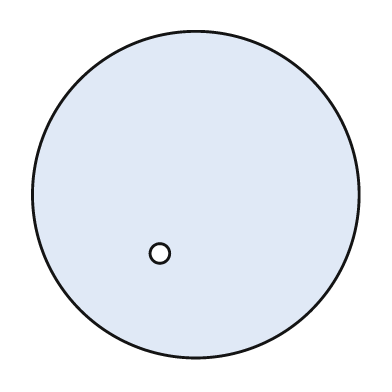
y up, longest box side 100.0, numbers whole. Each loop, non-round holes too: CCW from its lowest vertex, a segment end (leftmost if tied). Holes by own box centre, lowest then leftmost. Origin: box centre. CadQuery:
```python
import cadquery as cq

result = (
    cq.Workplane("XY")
    .moveTo(0.0, 0.0)
    .circle(50.0)
    .moveTo(-11.0, -18.0)
    .circle(3.0)
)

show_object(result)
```